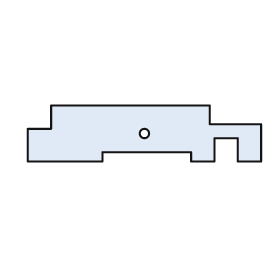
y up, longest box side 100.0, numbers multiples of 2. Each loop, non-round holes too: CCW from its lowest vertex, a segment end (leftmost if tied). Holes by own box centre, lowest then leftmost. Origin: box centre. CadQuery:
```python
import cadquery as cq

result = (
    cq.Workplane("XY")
    .moveTo(-50.0, -12.0)
    .lineTo(-18.0, -12.0)
    .lineTo(-18.0, -8.0)
    .lineTo(20.0, -8.0)
    .lineTo(20.0, -12.0)
    .lineTo(30.0, -12.0)
    .lineTo(30.0, -2.0)
    .lineTo(40.0, -2.0)
    .lineTo(40.0, -12.0)
    .lineTo(50.0, -12.0)
    .lineTo(50.0, 4.0)
    .lineTo(28.0, 4.0)
    .lineTo(28.0, 12.0)
    .lineTo(-40.0, 12.0)
    .lineTo(-40.0, 2.0)
    .lineTo(-50.0, 2.0)
    .close()
    .moveTo(0.0, 0.0)
    .circle(2.0)
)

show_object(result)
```